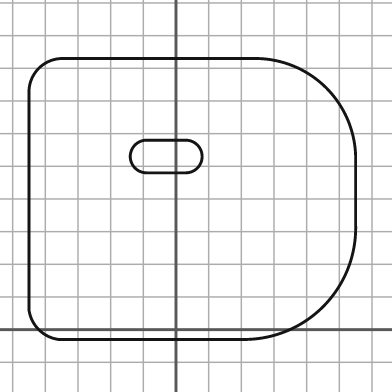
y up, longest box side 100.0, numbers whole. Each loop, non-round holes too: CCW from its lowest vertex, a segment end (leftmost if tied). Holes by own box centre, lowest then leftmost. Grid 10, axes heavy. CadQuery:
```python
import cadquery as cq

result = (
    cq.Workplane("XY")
    .moveTo(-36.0, -3.0)
    .lineTo(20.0, -3.0)
    .threePointArc((45.0, 7.0), (55.0, 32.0))
    .lineTo(55.0, 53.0)
    .threePointArc((46.0, 74.0), (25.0, 83.0))
    .lineTo(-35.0, 83.0)
    .threePointArc((-42.0, 80.0), (-45.0, 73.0))
    .lineTo(-45.0, 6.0)
    .threePointArc((-42.0, 0.0), (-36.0, -3.0))
    .close()
    .moveTo(-9.0, 48.0)
    .lineTo(3.0, 48.0)
    .threePointArc((8.0, 53.0), (3.0, 58.0))
    .lineTo(-9.0, 58.0)
    .threePointArc((-14.0, 53.0), (-9.0, 48.0))
    .close()
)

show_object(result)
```